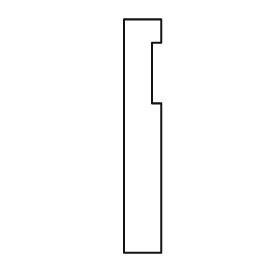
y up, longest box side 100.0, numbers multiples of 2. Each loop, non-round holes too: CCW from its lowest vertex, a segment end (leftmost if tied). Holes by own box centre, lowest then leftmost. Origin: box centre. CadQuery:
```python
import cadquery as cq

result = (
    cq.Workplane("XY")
    .moveTo(-8.0, -50.0)
    .lineTo(8.0, -50.0)
    .lineTo(8.0, 14.0)
    .lineTo(4.0, 14.0)
    .lineTo(4.0, 40.0)
    .lineTo(8.0, 40.0)
    .lineTo(8.0, 50.0)
    .lineTo(-8.0, 50.0)
    .close()
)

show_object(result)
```